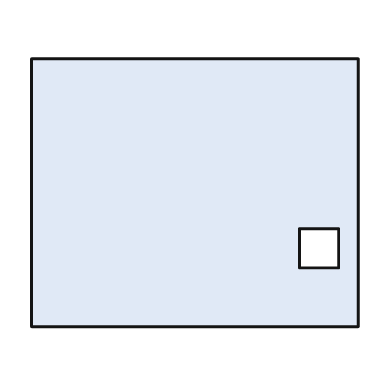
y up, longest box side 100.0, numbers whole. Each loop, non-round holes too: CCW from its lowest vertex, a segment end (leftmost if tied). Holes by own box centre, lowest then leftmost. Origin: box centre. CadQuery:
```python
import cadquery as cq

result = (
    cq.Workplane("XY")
    .moveTo(-50.0, -41.0)
    .lineTo(50.0, -41.0)
    .lineTo(50.0, 41.0)
    .lineTo(-50.0, 41.0)
    .close()
    .moveTo(32.0, -23.0)
    .lineTo(44.0, -23.0)
    .lineTo(44.0, -11.0)
    .lineTo(32.0, -11.0)
    .close()
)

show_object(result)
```